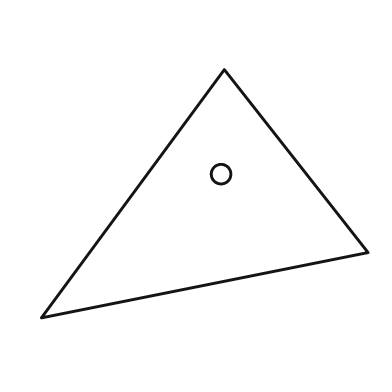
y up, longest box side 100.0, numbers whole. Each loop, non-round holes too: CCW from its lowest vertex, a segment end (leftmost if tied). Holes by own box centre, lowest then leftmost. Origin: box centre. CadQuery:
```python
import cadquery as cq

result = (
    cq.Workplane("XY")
    .moveTo(-50.0, -38.0)
    .lineTo(50.0, -18.0)
    .lineTo(6.0, 38.0)
    .close()
    .moveTo(5.0, 6.0)
    .circle(3.0)
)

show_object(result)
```